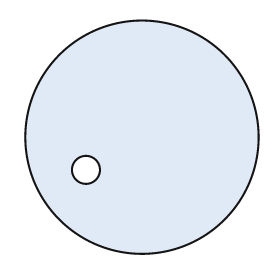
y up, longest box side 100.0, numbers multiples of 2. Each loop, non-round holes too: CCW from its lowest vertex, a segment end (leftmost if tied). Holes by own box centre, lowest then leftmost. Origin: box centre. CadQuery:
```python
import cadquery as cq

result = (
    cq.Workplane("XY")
    .moveTo(0.0, 0.0)
    .circle(50.0)
    .moveTo(-24.0, -14.0)
    .circle(6.0)
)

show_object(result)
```